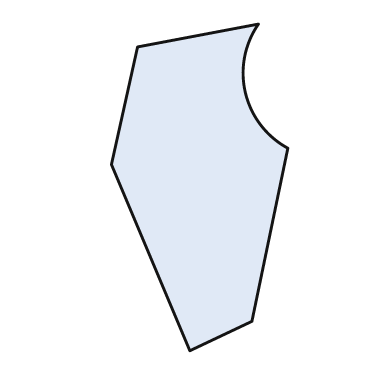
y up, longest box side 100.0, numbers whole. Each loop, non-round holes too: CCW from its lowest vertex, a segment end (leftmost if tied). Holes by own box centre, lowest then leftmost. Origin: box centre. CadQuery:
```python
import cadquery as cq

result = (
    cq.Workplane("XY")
    .moveTo(-3.0, -50.0)
    .lineTo(16.0, -41.0)
    .lineTo(27.0, 12.0)
    .threePointArc((14.0, 29.0), (18.0, 50.0))
    .lineTo(-19.0, 43.0)
    .lineTo(-27.0, 7.0)
    .close()
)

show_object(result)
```